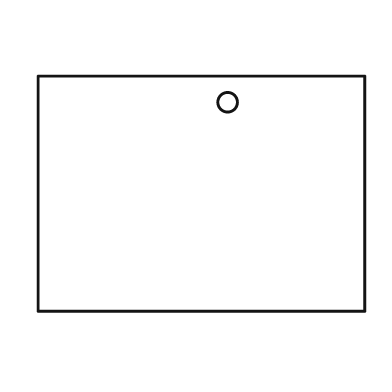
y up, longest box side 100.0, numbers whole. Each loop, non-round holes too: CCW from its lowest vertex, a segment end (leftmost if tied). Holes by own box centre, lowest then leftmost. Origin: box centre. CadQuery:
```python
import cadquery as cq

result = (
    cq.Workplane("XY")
    .moveTo(-50.0, -36.0)
    .lineTo(50.0, -36.0)
    .lineTo(50.0, 36.0)
    .lineTo(-50.0, 36.0)
    .close()
    .moveTo(8.0, 28.0)
    .circle(3.0)
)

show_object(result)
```